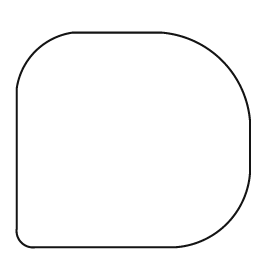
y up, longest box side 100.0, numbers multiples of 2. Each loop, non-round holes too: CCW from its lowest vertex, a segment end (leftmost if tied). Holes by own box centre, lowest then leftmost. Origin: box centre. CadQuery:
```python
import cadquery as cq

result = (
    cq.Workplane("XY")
    .moveTo(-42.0, -46.0)
    .lineTo(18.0, -46.0)
    .threePointArc((40.0, -36.0), (50.0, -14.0))
    .lineTo(50.0, 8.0)
    .threePointArc((38.0, 34.0), (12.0, 46.0))
    .lineTo(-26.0, 46.0)
    .threePointArc((-42.0, 38.0), (-50.0, 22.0))
    .lineTo(-50.0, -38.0)
    .threePointArc((-48.0, -44.0), (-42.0, -46.0))
    .close()
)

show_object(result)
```